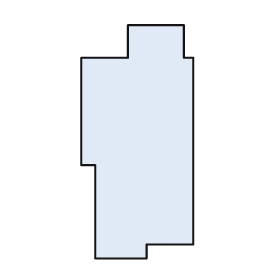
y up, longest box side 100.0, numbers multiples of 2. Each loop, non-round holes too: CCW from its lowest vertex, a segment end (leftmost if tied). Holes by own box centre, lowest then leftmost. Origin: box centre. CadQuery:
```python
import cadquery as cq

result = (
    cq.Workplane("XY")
    .moveTo(-18.0, -50.0)
    .lineTo(4.0, -50.0)
    .lineTo(4.0, -44.0)
    .lineTo(24.0, -44.0)
    .lineTo(24.0, 36.0)
    .lineTo(20.0, 36.0)
    .lineTo(20.0, 50.0)
    .lineTo(-4.0, 50.0)
    .lineTo(-4.0, 36.0)
    .lineTo(-24.0, 36.0)
    .lineTo(-24.0, -10.0)
    .lineTo(-18.0, -10.0)
    .close()
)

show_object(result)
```